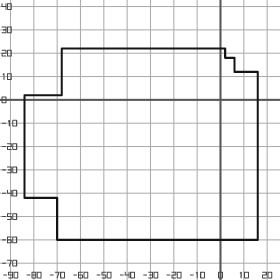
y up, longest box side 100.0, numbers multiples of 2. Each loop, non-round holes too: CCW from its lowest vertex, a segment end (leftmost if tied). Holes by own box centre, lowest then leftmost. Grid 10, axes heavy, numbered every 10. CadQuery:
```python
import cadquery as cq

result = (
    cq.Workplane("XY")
    .moveTo(-70.0, -60.0)
    .lineTo(16.0, -60.0)
    .lineTo(16.0, 12.0)
    .lineTo(6.0, 12.0)
    .lineTo(6.0, 18.0)
    .lineTo(2.0, 18.0)
    .lineTo(2.0, 22.0)
    .lineTo(-68.0, 22.0)
    .lineTo(-68.0, 2.0)
    .lineTo(-84.0, 2.0)
    .lineTo(-84.0, -42.0)
    .lineTo(-70.0, -42.0)
    .close()
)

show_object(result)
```